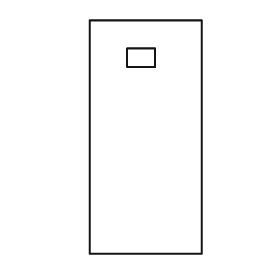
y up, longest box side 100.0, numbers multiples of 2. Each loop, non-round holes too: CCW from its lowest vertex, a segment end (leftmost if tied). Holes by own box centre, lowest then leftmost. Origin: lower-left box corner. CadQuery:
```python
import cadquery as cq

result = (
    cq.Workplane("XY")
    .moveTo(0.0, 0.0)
    .lineTo(48.0, 0.0)
    .lineTo(48.0, 100.0)
    .lineTo(0.0, 100.0)
    .close()
    .moveTo(16.0, 80.0)
    .lineTo(28.0, 80.0)
    .lineTo(28.0, 88.0)
    .lineTo(16.0, 88.0)
    .close()
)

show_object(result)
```